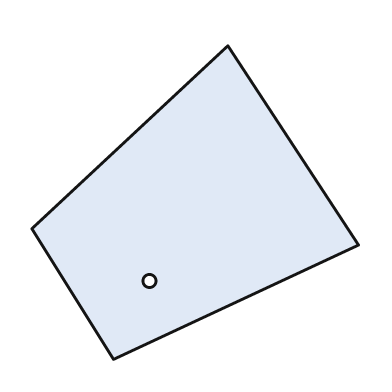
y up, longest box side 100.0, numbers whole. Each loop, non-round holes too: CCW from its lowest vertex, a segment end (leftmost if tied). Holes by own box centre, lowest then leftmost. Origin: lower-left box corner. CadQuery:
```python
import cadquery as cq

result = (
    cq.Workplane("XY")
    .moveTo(25.0, 0.0)
    .lineTo(100.0, 35.0)
    .lineTo(60.0, 96.0)
    .lineTo(0.0, 40.0)
    .close()
    .moveTo(36.0, 24.0)
    .circle(2.0)
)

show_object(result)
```